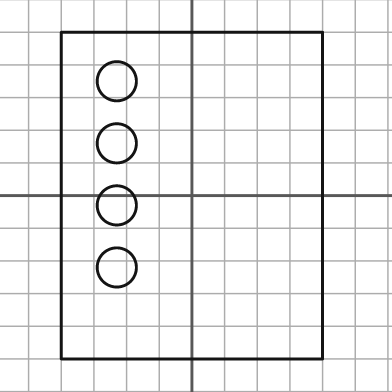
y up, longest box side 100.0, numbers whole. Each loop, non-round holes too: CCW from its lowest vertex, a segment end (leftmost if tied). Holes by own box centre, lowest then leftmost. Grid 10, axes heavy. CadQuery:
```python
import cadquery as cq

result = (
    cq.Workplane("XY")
    .moveTo(-40.0, -50.0)
    .lineTo(40.0, -50.0)
    .lineTo(40.0, 50.0)
    .lineTo(-40.0, 50.0)
    .close()
    .moveTo(-23.0, -22.0)
    .circle(6.0)
    .moveTo(-23.0, -3.0)
    .circle(6.0)
    .moveTo(-23.0, 16.0)
    .circle(6.0)
    .moveTo(-23.0, 35.0)
    .circle(6.0)
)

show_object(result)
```